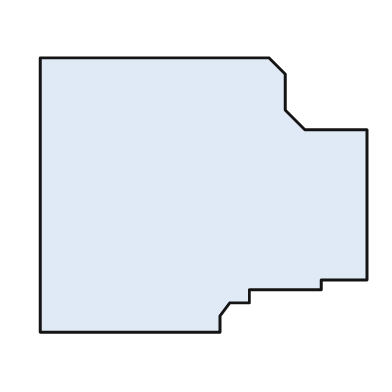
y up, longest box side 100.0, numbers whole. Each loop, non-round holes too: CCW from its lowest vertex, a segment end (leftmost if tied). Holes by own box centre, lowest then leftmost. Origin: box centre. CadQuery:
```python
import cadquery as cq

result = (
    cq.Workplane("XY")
    .moveTo(-50.0, -42.0)
    .lineTo(5.0, -42.0)
    .lineTo(5.0, -37.0)
    .lineTo(8.0, -33.0)
    .lineTo(14.0, -33.0)
    .lineTo(14.0, -29.0)
    .lineTo(36.0, -29.0)
    .lineTo(36.0, -26.0)
    .lineTo(50.0, -26.0)
    .lineTo(50.0, 20.0)
    .lineTo(31.0, 20.0)
    .lineTo(25.0, 26.0)
    .lineTo(25.0, 37.0)
    .lineTo(20.0, 42.0)
    .lineTo(-50.0, 42.0)
    .close()
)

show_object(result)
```